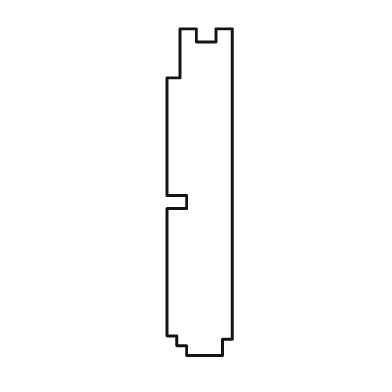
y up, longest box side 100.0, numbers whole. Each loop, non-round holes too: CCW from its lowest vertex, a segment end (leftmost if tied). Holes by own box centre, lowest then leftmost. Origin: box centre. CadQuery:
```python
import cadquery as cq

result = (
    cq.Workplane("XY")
    .moveTo(-4.0, -50.0)
    .lineTo(7.0, -50.0)
    .lineTo(7.0, -45.0)
    .lineTo(10.0, -45.0)
    .lineTo(10.0, 50.0)
    .lineTo(5.0, 50.0)
    .lineTo(5.0, 46.0)
    .lineTo(-1.0, 46.0)
    .lineTo(-1.0, 50.0)
    .lineTo(-6.0, 50.0)
    .lineTo(-6.0, 35.0)
    .lineTo(-10.0, 35.0)
    .lineTo(-10.0, -1.0)
    .lineTo(-4.0, -1.0)
    .lineTo(-4.0, -5.0)
    .lineTo(-10.0, -5.0)
    .lineTo(-10.0, -44.0)
    .lineTo(-7.0, -44.0)
    .lineTo(-7.0, -47.0)
    .lineTo(-4.0, -47.0)
    .close()
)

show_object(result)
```